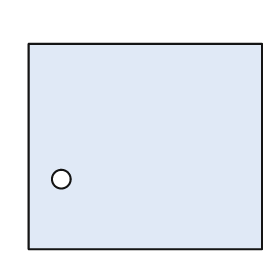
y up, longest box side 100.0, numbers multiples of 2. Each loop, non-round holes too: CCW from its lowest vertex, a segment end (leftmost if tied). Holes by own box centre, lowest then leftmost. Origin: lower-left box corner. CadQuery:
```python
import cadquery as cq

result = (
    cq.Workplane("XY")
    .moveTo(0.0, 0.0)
    .lineTo(100.0, 0.0)
    .lineTo(100.0, 88.0)
    .lineTo(0.0, 88.0)
    .close()
    .moveTo(14.0, 30.0)
    .circle(4.0)
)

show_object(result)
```